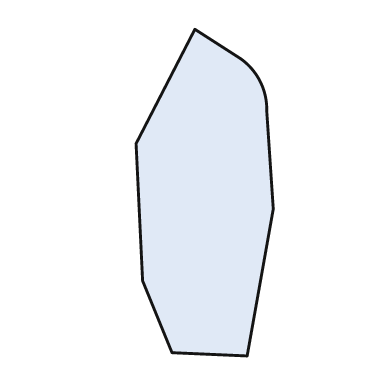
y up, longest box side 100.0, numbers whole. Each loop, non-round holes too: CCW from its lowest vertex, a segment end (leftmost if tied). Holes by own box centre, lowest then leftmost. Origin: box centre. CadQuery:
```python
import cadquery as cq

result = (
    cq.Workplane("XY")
    .moveTo(13.0, -50.0)
    .lineTo(21.0, -5.0)
    .lineTo(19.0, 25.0)
    .threePointArc((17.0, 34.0), (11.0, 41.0))
    .lineTo(-3.0, 50.0)
    .lineTo(-21.0, 15.0)
    .lineTo(-19.0, -27.0)
    .lineTo(-10.0, -49.0)
    .close()
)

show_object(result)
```